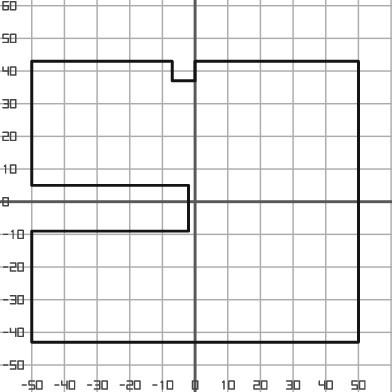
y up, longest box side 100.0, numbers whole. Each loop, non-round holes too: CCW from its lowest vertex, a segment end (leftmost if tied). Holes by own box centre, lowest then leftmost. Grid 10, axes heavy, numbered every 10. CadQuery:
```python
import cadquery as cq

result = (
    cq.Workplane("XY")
    .moveTo(-50.0, -43.0)
    .lineTo(50.0, -43.0)
    .lineTo(50.0, 43.0)
    .lineTo(0.0, 43.0)
    .lineTo(0.0, 37.0)
    .lineTo(-7.0, 37.0)
    .lineTo(-7.0, 43.0)
    .lineTo(-50.0, 43.0)
    .lineTo(-50.0, 5.0)
    .lineTo(-2.0, 5.0)
    .lineTo(-2.0, -9.0)
    .lineTo(-50.0, -9.0)
    .close()
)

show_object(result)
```